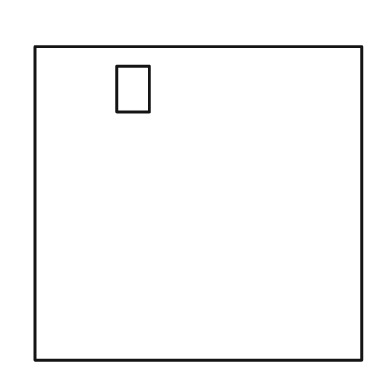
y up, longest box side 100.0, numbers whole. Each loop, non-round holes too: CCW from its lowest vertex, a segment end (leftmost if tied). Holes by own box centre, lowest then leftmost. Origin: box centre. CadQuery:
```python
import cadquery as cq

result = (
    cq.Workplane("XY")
    .moveTo(-50.0, -48.0)
    .lineTo(50.0, -48.0)
    .lineTo(50.0, 48.0)
    .lineTo(-50.0, 48.0)
    .close()
    .moveTo(-25.0, 28.0)
    .lineTo(-15.0, 28.0)
    .lineTo(-15.0, 42.0)
    .lineTo(-25.0, 42.0)
    .close()
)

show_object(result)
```